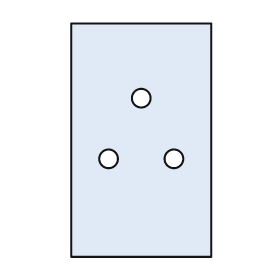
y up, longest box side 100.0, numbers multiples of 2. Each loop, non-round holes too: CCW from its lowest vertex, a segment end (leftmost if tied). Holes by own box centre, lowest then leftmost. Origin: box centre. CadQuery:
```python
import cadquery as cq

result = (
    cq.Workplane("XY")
    .moveTo(-30.0, -50.0)
    .lineTo(30.0, -50.0)
    .lineTo(30.0, 50.0)
    .lineTo(-30.0, 50.0)
    .close()
    .moveTo(-14.0, -8.0)
    .circle(4.0)
    .moveTo(14.0, -8.0)
    .circle(4.0)
    .moveTo(0.0, 18.0)
    .circle(4.0)
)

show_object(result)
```